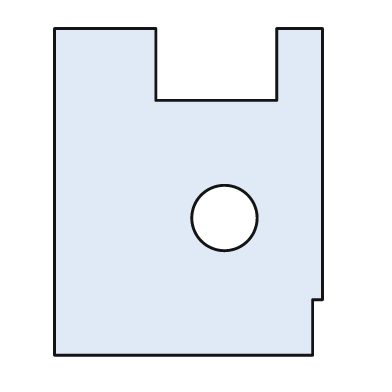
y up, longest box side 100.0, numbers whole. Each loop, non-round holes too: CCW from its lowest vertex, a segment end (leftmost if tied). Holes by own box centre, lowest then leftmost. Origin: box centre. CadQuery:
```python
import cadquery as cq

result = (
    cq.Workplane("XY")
    .moveTo(-41.0, -50.0)
    .lineTo(38.0, -50.0)
    .lineTo(38.0, -33.0)
    .lineTo(41.0, -33.0)
    .lineTo(41.0, 50.0)
    .lineTo(27.0, 50.0)
    .lineTo(27.0, 28.0)
    .lineTo(-10.0, 28.0)
    .lineTo(-10.0, 50.0)
    .lineTo(-41.0, 50.0)
    .close()
    .moveTo(11.0, -8.0)
    .circle(10.0)
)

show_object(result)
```